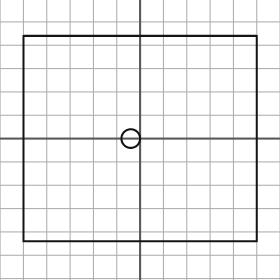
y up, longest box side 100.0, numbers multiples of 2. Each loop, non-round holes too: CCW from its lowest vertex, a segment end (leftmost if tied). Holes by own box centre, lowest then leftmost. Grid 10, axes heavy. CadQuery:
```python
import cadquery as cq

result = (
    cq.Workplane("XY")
    .moveTo(-50.0, -44.0)
    .lineTo(50.0, -44.0)
    .lineTo(50.0, 44.0)
    .lineTo(-50.0, 44.0)
    .close()
    .moveTo(-4.0, 0.0)
    .circle(4.0)
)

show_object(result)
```